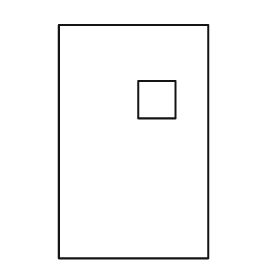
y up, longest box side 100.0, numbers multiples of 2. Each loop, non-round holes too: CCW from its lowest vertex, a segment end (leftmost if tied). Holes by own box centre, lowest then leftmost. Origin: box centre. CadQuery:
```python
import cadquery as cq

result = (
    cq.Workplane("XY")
    .moveTo(-32.0, -50.0)
    .lineTo(32.0, -50.0)
    .lineTo(32.0, 50.0)
    .lineTo(-32.0, 50.0)
    .close()
    .moveTo(2.0, 10.0)
    .lineTo(18.0, 10.0)
    .lineTo(18.0, 26.0)
    .lineTo(2.0, 26.0)
    .close()
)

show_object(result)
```